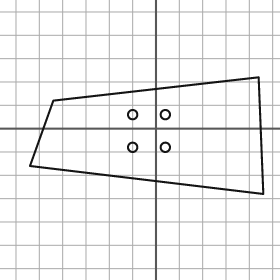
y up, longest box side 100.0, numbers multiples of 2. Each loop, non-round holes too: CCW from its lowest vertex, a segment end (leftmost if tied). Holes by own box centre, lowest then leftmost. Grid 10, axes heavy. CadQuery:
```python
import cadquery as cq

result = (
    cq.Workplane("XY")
    .moveTo(46.0, -28.0)
    .lineTo(44.0, 22.0)
    .lineTo(-44.0, 12.0)
    .lineTo(-54.0, -16.0)
    .close()
    .moveTo(-10.0, -8.0)
    .circle(2.0)
    .moveTo(4.0, -8.0)
    .circle(2.0)
    .moveTo(-10.0, 6.0)
    .circle(2.0)
    .moveTo(4.0, 6.0)
    .circle(2.0)
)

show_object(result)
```